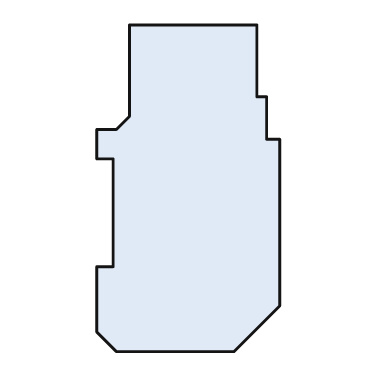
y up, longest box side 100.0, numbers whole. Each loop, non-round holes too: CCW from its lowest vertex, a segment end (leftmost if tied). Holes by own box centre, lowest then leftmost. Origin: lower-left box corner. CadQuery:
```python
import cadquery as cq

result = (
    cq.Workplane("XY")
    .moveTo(6.0, 0.0)
    .lineTo(42.0, 0.0)
    .lineTo(56.0, 14.0)
    .lineTo(56.0, 65.0)
    .lineTo(52.0, 65.0)
    .lineTo(52.0, 78.0)
    .lineTo(49.0, 78.0)
    .lineTo(49.0, 100.0)
    .lineTo(10.0, 100.0)
    .lineTo(10.0, 72.0)
    .lineTo(6.0, 68.0)
    .lineTo(0.0, 68.0)
    .lineTo(0.0, 59.0)
    .lineTo(5.0, 59.0)
    .lineTo(5.0, 26.0)
    .lineTo(0.0, 26.0)
    .lineTo(0.0, 6.0)
    .close()
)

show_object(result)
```